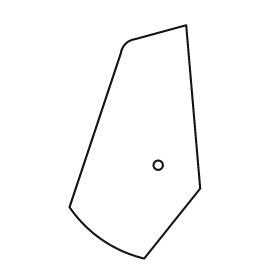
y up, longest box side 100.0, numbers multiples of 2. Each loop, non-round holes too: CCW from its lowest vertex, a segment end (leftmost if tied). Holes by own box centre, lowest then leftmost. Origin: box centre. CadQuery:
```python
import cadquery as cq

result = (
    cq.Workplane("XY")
    .moveTo(4.0, -50.0)
    .lineTo(28.0, -20.0)
    .lineTo(22.0, 50.0)
    .lineTo(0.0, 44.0)
    .threePointArc((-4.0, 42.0), (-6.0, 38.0))
    .lineTo(-28.0, -28.0)
    .threePointArc((-14.0, -42.0), (4.0, -50.0))
    .close()
    .moveTo(10.0, -10.0)
    .circle(2.0)
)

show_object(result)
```